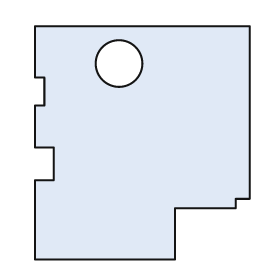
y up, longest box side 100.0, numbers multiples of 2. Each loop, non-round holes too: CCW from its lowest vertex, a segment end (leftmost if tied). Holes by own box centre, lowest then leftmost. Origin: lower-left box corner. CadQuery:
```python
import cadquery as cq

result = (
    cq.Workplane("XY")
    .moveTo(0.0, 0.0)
    .lineTo(60.0, 0.0)
    .lineTo(60.0, 22.0)
    .lineTo(86.0, 22.0)
    .lineTo(86.0, 26.0)
    .lineTo(92.0, 26.0)
    .lineTo(92.0, 100.0)
    .lineTo(0.0, 100.0)
    .lineTo(0.0, 78.0)
    .lineTo(4.0, 78.0)
    .lineTo(4.0, 66.0)
    .lineTo(0.0, 66.0)
    .lineTo(0.0, 48.0)
    .lineTo(8.0, 48.0)
    .lineTo(8.0, 34.0)
    .lineTo(0.0, 34.0)
    .close()
    .moveTo(36.0, 84.0)
    .circle(10.0)
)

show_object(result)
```